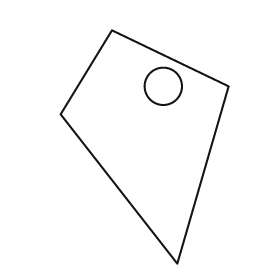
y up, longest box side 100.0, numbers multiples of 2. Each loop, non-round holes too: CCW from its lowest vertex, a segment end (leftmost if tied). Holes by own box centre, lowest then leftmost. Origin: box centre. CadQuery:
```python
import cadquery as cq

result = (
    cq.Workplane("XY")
    .moveTo(14.0, -50.0)
    .lineTo(36.0, 26.0)
    .lineTo(-14.0, 50.0)
    .lineTo(-36.0, 14.0)
    .close()
    .moveTo(8.0, 26.0)
    .circle(8.0)
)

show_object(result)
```